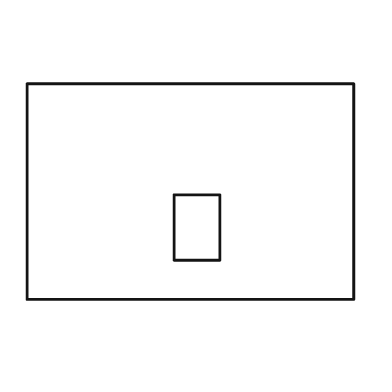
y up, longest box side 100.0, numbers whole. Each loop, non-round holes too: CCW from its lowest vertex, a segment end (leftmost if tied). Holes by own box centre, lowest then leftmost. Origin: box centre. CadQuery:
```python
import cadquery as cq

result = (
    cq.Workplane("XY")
    .moveTo(-50.0, -33.0)
    .lineTo(50.0, -33.0)
    .lineTo(50.0, 33.0)
    .lineTo(-50.0, 33.0)
    .close()
    .moveTo(-5.0, -21.0)
    .lineTo(9.0, -21.0)
    .lineTo(9.0, -1.0)
    .lineTo(-5.0, -1.0)
    .close()
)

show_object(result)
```